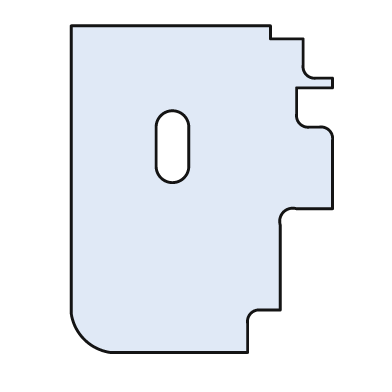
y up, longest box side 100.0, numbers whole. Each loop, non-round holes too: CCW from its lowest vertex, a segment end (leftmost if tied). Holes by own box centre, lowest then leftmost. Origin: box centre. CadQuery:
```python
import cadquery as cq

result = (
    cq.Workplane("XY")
    .moveTo(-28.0, -50.0)
    .lineTo(14.0, -50.0)
    .lineTo(14.0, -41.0)
    .threePointArc((15.0, -38.0), (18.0, -37.0))
    .lineTo(24.0, -37.0)
    .lineTo(24.0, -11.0)
    .threePointArc((25.0, -7.0), (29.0, -6.0))
    .lineTo(40.0, -6.0)
    .lineTo(40.0, 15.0)
    .threePointArc((39.0, 18.0), (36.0, 19.0))
    .lineTo(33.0, 19.0)
    .threePointArc((30.0, 20.0), (29.0, 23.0))
    .lineTo(29.0, 31.0)
    .lineTo(40.0, 31.0)
    .lineTo(40.0, 34.0)
    .lineTo(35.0, 34.0)
    .threePointArc((32.0, 35.0), (31.0, 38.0))
    .lineTo(31.0, 46.0)
    .lineTo(21.0, 46.0)
    .lineTo(21.0, 50.0)
    .lineTo(-40.0, 50.0)
    .lineTo(-40.0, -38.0)
    .threePointArc((-36.0, -46.0), (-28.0, -50.0))
    .close()
    .moveTo(-14.0, 7.0)
    .threePointArc((-9.0, 2.0), (-4.0, 7.0))
    .lineTo(-4.0, 19.0)
    .threePointArc((-9.0, 24.0), (-14.0, 19.0))
    .close()
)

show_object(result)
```